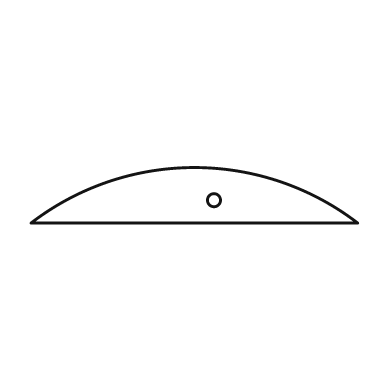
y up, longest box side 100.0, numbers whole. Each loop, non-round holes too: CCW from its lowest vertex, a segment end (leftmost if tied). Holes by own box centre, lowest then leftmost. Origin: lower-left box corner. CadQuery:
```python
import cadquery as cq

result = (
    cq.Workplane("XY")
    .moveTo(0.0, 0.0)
    .lineTo(100.0, 0.0)
    .threePointArc((50.0, 17.0), (0.0, 0.0))
    .close()
    .moveTo(56.0, 7.0)
    .circle(2.0)
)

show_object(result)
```